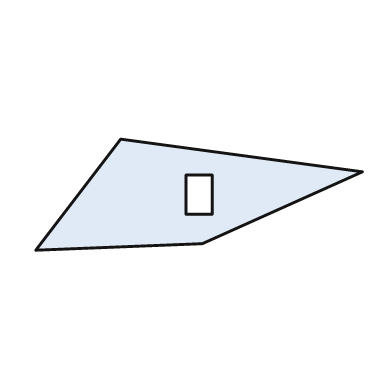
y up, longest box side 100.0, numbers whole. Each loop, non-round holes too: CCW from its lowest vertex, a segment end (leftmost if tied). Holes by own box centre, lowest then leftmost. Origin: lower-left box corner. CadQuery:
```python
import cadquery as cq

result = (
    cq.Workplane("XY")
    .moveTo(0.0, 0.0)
    .lineTo(51.0, 2.0)
    .lineTo(100.0, 24.0)
    .lineTo(26.0, 34.0)
    .close()
    .moveTo(46.0, 11.0)
    .lineTo(54.0, 11.0)
    .lineTo(54.0, 23.0)
    .lineTo(46.0, 23.0)
    .close()
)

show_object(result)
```